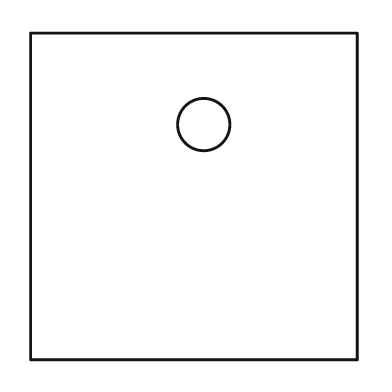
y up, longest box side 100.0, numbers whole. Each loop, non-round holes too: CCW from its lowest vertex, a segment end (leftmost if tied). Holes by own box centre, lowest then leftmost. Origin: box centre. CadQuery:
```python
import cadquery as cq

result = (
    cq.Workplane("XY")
    .moveTo(-50.0, -50.0)
    .lineTo(50.0, -50.0)
    .lineTo(50.0, 50.0)
    .lineTo(-50.0, 50.0)
    .close()
    .moveTo(3.0, 22.0)
    .circle(8.0)
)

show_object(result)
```